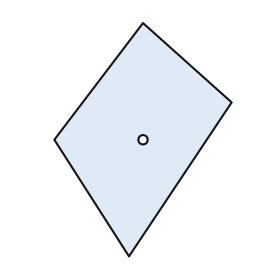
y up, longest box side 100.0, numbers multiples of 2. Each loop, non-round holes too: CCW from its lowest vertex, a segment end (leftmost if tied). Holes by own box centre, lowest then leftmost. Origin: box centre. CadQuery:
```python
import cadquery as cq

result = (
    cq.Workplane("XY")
    .moveTo(-6.0, -50.0)
    .lineTo(38.0, 16.0)
    .lineTo(0.0, 50.0)
    .lineTo(-38.0, 0.0)
    .close()
    .moveTo(0.0, 0.0)
    .circle(2.0)
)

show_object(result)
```